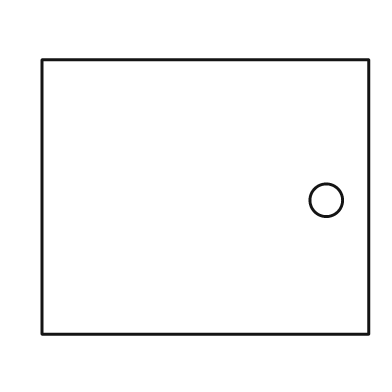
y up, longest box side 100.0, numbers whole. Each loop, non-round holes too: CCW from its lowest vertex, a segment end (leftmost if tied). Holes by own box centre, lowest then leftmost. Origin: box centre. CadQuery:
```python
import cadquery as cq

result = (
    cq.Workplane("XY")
    .moveTo(-50.0, -42.0)
    .lineTo(50.0, -42.0)
    .lineTo(50.0, 42.0)
    .lineTo(-50.0, 42.0)
    .close()
    .moveTo(37.0, -1.0)
    .circle(5.0)
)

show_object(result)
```